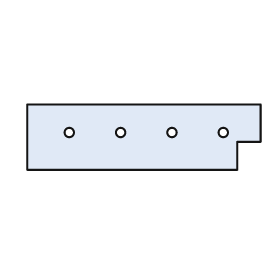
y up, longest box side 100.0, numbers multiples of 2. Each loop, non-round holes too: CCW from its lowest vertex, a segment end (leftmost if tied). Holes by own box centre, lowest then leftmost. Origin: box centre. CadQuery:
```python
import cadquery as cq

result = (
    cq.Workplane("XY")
    .moveTo(-50.0, -14.0)
    .lineTo(40.0, -14.0)
    .lineTo(40.0, -2.0)
    .lineTo(50.0, -2.0)
    .lineTo(50.0, 14.0)
    .lineTo(-50.0, 14.0)
    .close()
    .moveTo(-32.0, 2.0)
    .circle(2.0)
    .moveTo(-10.0, 2.0)
    .circle(2.0)
    .moveTo(12.0, 2.0)
    .circle(2.0)
    .moveTo(34.0, 2.0)
    .circle(2.0)
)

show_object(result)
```